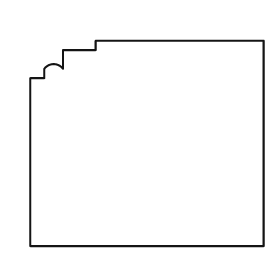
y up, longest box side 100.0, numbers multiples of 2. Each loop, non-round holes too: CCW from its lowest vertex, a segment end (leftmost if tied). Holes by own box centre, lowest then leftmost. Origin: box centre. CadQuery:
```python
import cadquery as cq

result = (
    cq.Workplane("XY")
    .moveTo(-50.0, -44.0)
    .lineTo(50.0, -44.0)
    .lineTo(50.0, 44.0)
    .lineTo(-22.0, 44.0)
    .lineTo(-22.0, 40.0)
    .lineTo(-36.0, 40.0)
    .lineTo(-36.0, 32.0)
    .threePointArc((-40.0, 34.0), (-44.0, 32.0))
    .lineTo(-44.0, 28.0)
    .lineTo(-50.0, 28.0)
    .close()
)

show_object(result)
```